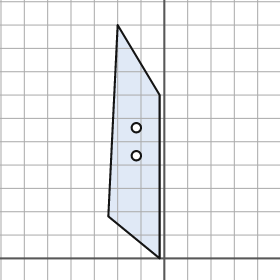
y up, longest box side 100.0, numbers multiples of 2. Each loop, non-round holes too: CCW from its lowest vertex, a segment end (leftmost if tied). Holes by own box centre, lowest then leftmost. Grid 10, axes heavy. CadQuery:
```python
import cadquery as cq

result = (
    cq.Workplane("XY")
    .moveTo(-2.0, 0.0)
    .lineTo(-2.0, 70.0)
    .lineTo(-20.0, 100.0)
    .lineTo(-24.0, 18.0)
    .close()
    .moveTo(-12.0, 44.0)
    .circle(2.0)
    .moveTo(-12.0, 56.0)
    .circle(2.0)
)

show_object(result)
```